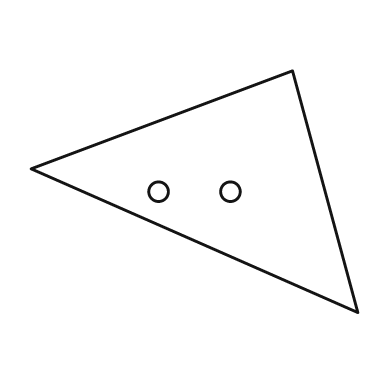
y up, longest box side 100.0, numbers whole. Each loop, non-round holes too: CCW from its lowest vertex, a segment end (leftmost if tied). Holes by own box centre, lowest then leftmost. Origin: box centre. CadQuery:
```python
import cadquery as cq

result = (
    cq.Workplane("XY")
    .moveTo(50.0, -37.0)
    .lineTo(30.0, 37.0)
    .lineTo(-50.0, 7.0)
    .close()
    .moveTo(-11.0, 0.0)
    .circle(3.0)
    .moveTo(11.0, 0.0)
    .circle(3.0)
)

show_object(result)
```